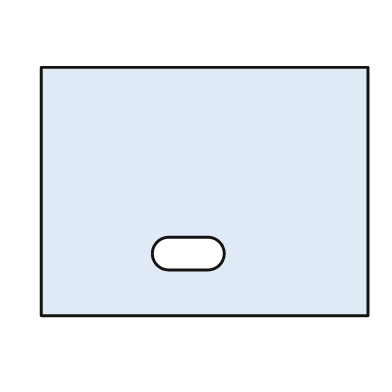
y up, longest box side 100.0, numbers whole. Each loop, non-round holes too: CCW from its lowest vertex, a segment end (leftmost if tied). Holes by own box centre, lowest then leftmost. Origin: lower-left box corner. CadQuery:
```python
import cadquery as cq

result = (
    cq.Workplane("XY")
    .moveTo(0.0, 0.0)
    .lineTo(100.0, 0.0)
    .lineTo(100.0, 76.0)
    .lineTo(0.0, 76.0)
    .close()
    .moveTo(39.0, 14.0)
    .lineTo(51.0, 14.0)
    .threePointArc((56.0, 19.0), (51.0, 24.0))
    .lineTo(39.0, 24.0)
    .threePointArc((34.0, 19.0), (39.0, 14.0))
    .close()
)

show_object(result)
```